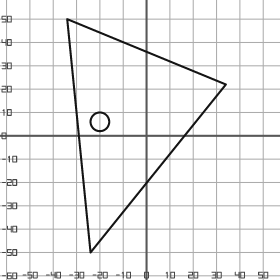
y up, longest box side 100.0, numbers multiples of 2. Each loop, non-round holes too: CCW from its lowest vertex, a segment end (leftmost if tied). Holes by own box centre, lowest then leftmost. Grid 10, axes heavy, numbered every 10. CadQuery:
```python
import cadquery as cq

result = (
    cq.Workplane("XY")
    .moveTo(-24.0, -50.0)
    .lineTo(34.0, 22.0)
    .lineTo(-34.0, 50.0)
    .close()
    .moveTo(-20.0, 6.0)
    .circle(4.0)
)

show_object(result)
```